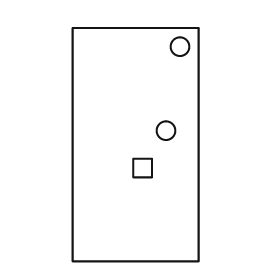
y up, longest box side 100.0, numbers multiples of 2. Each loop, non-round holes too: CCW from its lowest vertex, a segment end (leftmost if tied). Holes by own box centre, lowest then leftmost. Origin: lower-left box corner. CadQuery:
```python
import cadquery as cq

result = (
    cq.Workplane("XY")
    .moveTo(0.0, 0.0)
    .lineTo(54.0, 0.0)
    .lineTo(54.0, 100.0)
    .lineTo(0.0, 100.0)
    .close()
    .moveTo(26.0, 36.0)
    .lineTo(34.0, 36.0)
    .lineTo(34.0, 44.0)
    .lineTo(26.0, 44.0)
    .close()
    .moveTo(40.0, 56.0)
    .circle(4.0)
    .moveTo(46.0, 92.0)
    .circle(4.0)
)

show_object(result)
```